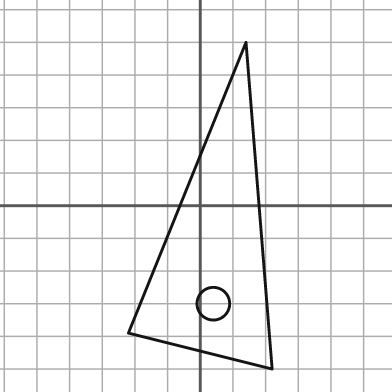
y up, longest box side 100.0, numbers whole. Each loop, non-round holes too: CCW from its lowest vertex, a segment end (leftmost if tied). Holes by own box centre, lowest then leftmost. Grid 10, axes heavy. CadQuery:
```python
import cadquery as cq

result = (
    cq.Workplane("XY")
    .moveTo(22.0, -50.0)
    .lineTo(14.0, 50.0)
    .lineTo(-22.0, -39.0)
    .close()
    .moveTo(4.0, -30.0)
    .circle(5.0)
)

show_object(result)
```